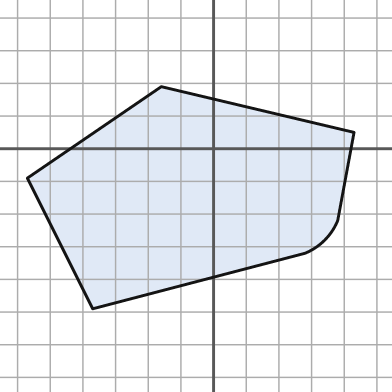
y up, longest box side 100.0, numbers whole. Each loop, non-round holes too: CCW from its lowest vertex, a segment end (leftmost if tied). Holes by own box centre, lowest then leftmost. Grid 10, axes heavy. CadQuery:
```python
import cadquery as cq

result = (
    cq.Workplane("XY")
    .moveTo(-37.0, -49.0)
    .lineTo(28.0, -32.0)
    .threePointArc((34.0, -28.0), (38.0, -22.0))
    .lineTo(43.0, 5.0)
    .lineTo(-16.0, 19.0)
    .lineTo(-57.0, -9.0)
    .close()
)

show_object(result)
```